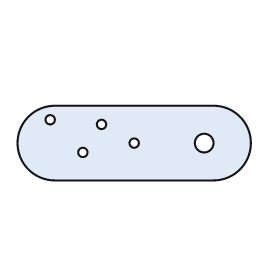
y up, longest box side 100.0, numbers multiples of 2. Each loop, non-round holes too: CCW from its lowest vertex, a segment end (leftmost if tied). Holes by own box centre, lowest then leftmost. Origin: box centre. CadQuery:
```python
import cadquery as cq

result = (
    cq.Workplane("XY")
    .moveTo(-34.0, -16.0)
    .lineTo(34.0, -16.0)
    .threePointArc((50.0, 0.0), (34.0, 16.0))
    .lineTo(-34.0, 16.0)
    .threePointArc((-50.0, 0.0), (-34.0, -16.0))
    .close()
    .moveTo(-22.0, -4.0)
    .circle(2.0)
    .moveTo(0.0, 0.0)
    .circle(2.0)
    .moveTo(30.0, 0.0)
    .circle(4.0)
    .moveTo(-14.0, 8.0)
    .circle(2.0)
    .moveTo(-36.0, 10.0)
    .circle(2.0)
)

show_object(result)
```